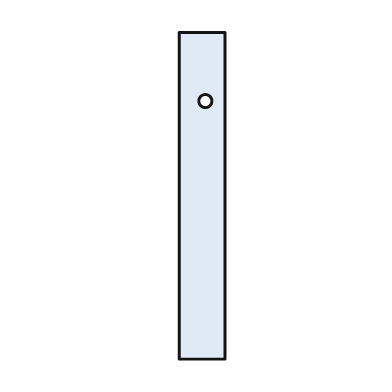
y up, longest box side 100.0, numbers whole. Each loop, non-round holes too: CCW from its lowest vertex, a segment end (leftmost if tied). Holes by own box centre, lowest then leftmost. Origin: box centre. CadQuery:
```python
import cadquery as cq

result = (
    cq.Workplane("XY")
    .moveTo(-7.0, -50.0)
    .lineTo(7.0, -50.0)
    .lineTo(7.0, 50.0)
    .lineTo(-7.0, 50.0)
    .close()
    .moveTo(1.0, 29.0)
    .circle(2.0)
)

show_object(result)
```